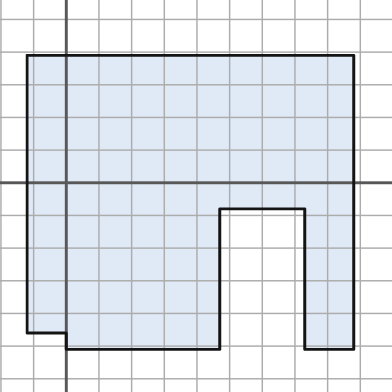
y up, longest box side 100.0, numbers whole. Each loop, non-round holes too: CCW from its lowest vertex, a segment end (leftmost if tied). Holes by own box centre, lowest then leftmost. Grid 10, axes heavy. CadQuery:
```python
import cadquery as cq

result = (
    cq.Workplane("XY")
    .moveTo(0.0, -51.0)
    .lineTo(47.0, -51.0)
    .lineTo(47.0, -8.0)
    .lineTo(73.0, -8.0)
    .lineTo(73.0, -51.0)
    .lineTo(88.0, -51.0)
    .lineTo(88.0, 39.0)
    .lineTo(-12.0, 39.0)
    .lineTo(-12.0, -46.0)
    .lineTo(0.0, -46.0)
    .close()
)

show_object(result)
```